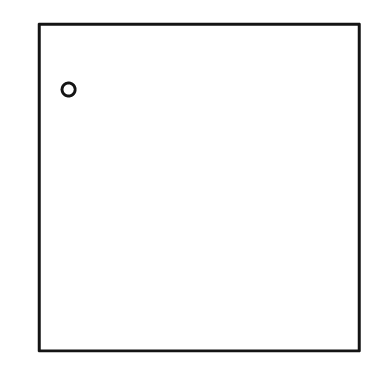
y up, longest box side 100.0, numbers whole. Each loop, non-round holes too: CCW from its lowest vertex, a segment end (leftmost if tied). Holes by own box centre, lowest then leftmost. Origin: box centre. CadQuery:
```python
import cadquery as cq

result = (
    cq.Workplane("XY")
    .moveTo(-49.0, -50.0)
    .lineTo(49.0, -50.0)
    .lineTo(49.0, 50.0)
    .lineTo(-49.0, 50.0)
    .close()
    .moveTo(-40.0, 30.0)
    .circle(2.0)
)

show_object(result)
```